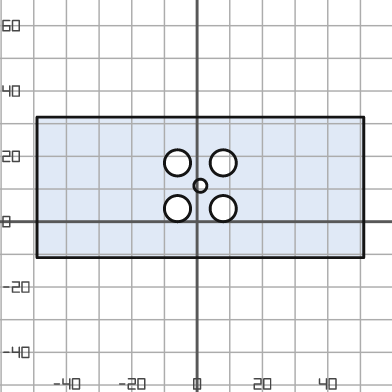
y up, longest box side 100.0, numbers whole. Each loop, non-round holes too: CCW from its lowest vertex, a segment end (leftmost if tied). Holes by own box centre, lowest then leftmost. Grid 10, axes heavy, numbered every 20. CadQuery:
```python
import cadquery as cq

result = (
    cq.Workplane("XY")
    .moveTo(-49.0, -11.0)
    .lineTo(51.0, -11.0)
    .lineTo(51.0, 32.0)
    .lineTo(-49.0, 32.0)
    .close()
    .moveTo(-6.0, 4.0)
    .circle(4.0)
    .moveTo(8.0, 4.0)
    .circle(4.0)
    .moveTo(1.0, 11.0)
    .circle(2.0)
    .moveTo(-6.0, 18.0)
    .circle(4.0)
    .moveTo(8.0, 18.0)
    .circle(4.0)
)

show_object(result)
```